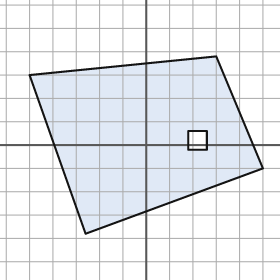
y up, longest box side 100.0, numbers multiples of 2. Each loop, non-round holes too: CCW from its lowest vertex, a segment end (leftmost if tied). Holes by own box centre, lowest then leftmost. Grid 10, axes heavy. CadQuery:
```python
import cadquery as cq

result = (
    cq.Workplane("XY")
    .moveTo(-26.0, -38.0)
    .lineTo(50.0, -10.0)
    .lineTo(30.0, 38.0)
    .lineTo(-50.0, 30.0)
    .close()
    .moveTo(18.0, -2.0)
    .lineTo(26.0, -2.0)
    .lineTo(26.0, 6.0)
    .lineTo(18.0, 6.0)
    .close()
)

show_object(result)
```